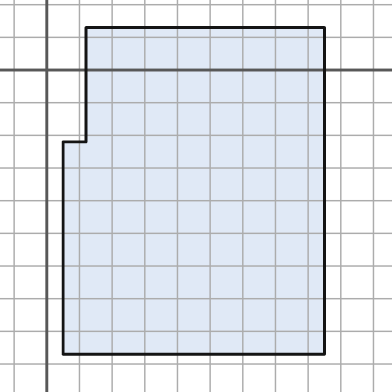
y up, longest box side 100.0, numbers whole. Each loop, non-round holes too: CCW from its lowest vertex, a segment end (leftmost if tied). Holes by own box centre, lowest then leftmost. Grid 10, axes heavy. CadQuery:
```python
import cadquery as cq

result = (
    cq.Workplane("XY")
    .moveTo(5.0, -87.0)
    .lineTo(85.0, -87.0)
    .lineTo(85.0, 13.0)
    .lineTo(12.0, 13.0)
    .lineTo(12.0, -22.0)
    .lineTo(5.0, -22.0)
    .close()
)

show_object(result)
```